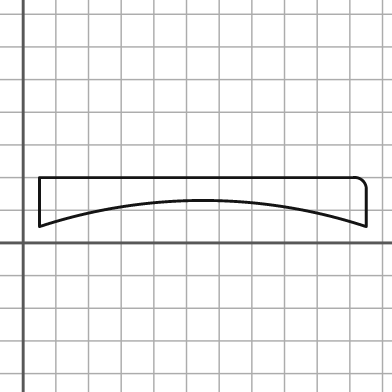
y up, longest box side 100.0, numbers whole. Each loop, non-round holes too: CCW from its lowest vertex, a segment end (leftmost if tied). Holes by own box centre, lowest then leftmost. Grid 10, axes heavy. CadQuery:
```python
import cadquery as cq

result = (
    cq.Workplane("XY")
    .moveTo(5.0, 5.0)
    .threePointArc((55.0, 13.0), (105.0, 5.0))
    .lineTo(105.0, 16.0)
    .threePointArc((104.0, 19.0), (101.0, 20.0))
    .lineTo(5.0, 20.0)
    .close()
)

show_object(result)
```